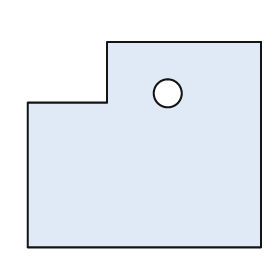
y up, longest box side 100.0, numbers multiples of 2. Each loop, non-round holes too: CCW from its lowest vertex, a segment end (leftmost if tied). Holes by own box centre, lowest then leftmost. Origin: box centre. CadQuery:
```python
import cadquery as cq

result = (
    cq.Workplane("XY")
    .moveTo(-50.0, -44.0)
    .lineTo(50.0, -44.0)
    .lineTo(50.0, 44.0)
    .lineTo(-16.0, 44.0)
    .lineTo(-16.0, 18.0)
    .lineTo(-50.0, 18.0)
    .close()
    .moveTo(10.0, 22.0)
    .circle(6.0)
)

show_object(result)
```